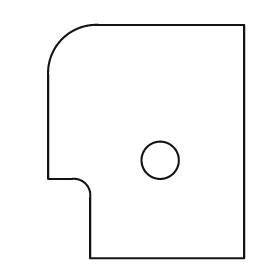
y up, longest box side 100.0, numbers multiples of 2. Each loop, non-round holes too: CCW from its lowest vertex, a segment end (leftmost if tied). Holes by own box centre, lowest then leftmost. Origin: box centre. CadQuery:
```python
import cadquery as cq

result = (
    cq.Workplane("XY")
    .moveTo(-24.0, -50.0)
    .lineTo(42.0, -50.0)
    .lineTo(42.0, 50.0)
    .lineTo(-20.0, 50.0)
    .threePointArc((-36.0, 44.0), (-42.0, 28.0))
    .lineTo(-42.0, -16.0)
    .lineTo(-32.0, -16.0)
    .threePointArc((-26.0, -18.0), (-24.0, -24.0))
    .close()
    .moveTo(6.0, -8.0)
    .circle(8.0)
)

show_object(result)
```